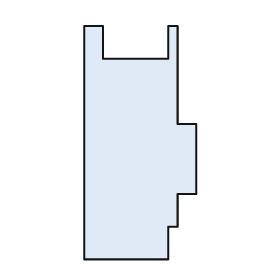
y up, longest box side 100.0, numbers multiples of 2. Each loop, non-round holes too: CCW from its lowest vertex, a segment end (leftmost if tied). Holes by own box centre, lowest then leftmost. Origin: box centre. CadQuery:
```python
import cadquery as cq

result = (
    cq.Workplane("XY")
    .moveTo(-24.0, -50.0)
    .lineTo(12.0, -50.0)
    .lineTo(12.0, -36.0)
    .lineTo(16.0, -36.0)
    .lineTo(16.0, -22.0)
    .lineTo(24.0, -22.0)
    .lineTo(24.0, 8.0)
    .lineTo(16.0, 8.0)
    .lineTo(16.0, 50.0)
    .lineTo(12.0, 50.0)
    .lineTo(12.0, 36.0)
    .lineTo(-16.0, 36.0)
    .lineTo(-16.0, 50.0)
    .lineTo(-24.0, 50.0)
    .close()
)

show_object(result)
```